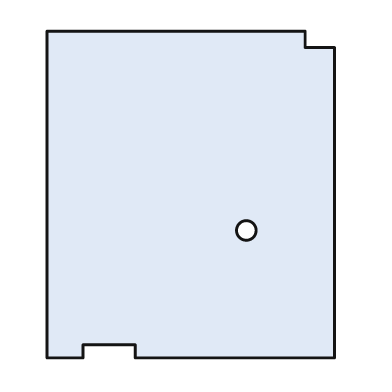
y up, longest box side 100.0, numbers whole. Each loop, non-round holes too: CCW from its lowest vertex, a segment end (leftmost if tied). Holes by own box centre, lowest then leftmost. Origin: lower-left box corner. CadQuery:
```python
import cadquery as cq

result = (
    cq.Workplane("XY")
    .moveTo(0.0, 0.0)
    .lineTo(11.0, 0.0)
    .lineTo(11.0, 4.0)
    .lineTo(27.0, 4.0)
    .lineTo(27.0, 0.0)
    .lineTo(88.0, 0.0)
    .lineTo(88.0, 95.0)
    .lineTo(79.0, 95.0)
    .lineTo(79.0, 100.0)
    .lineTo(0.0, 100.0)
    .close()
    .moveTo(61.0, 39.0)
    .circle(3.0)
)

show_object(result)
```